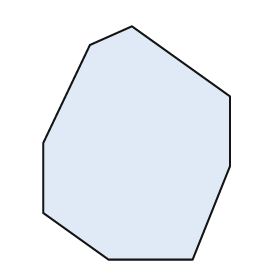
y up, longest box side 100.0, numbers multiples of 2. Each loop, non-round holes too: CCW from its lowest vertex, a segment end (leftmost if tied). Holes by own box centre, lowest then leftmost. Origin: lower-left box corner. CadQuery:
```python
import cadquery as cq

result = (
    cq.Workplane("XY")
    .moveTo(28.0, 0.0)
    .lineTo(64.0, 0.0)
    .lineTo(80.0, 40.0)
    .lineTo(80.0, 70.0)
    .lineTo(38.0, 100.0)
    .lineTo(20.0, 92.0)
    .lineTo(0.0, 50.0)
    .lineTo(0.0, 20.0)
    .close()
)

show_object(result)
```